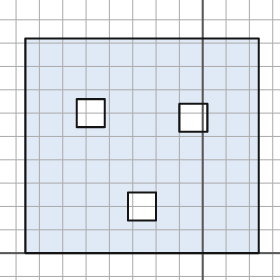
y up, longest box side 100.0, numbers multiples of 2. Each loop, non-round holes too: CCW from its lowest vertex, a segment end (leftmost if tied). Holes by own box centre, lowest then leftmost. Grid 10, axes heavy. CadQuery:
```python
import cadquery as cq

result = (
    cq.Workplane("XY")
    .moveTo(-76.0, 0.0)
    .lineTo(24.0, 0.0)
    .lineTo(24.0, 92.0)
    .lineTo(-76.0, 92.0)
    .close()
    .moveTo(-32.0, 14.0)
    .lineTo(-20.0, 14.0)
    .lineTo(-20.0, 26.0)
    .lineTo(-32.0, 26.0)
    .close()
    .moveTo(-10.0, 52.0)
    .lineTo(2.0, 52.0)
    .lineTo(2.0, 64.0)
    .lineTo(-10.0, 64.0)
    .close()
    .moveTo(-54.0, 54.0)
    .lineTo(-42.0, 54.0)
    .lineTo(-42.0, 66.0)
    .lineTo(-54.0, 66.0)
    .close()
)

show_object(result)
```